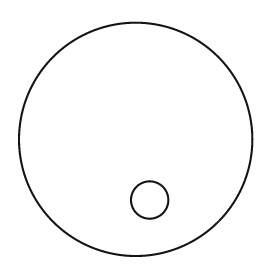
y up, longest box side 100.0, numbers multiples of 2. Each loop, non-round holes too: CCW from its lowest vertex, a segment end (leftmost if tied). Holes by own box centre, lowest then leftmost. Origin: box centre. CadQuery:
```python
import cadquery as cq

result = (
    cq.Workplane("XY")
    .moveTo(0.0, 0.0)
    .circle(50.0)
    .moveTo(6.0, -26.0)
    .circle(8.0)
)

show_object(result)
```